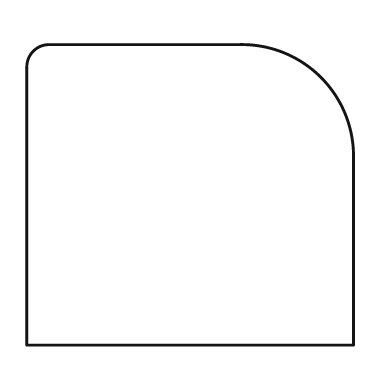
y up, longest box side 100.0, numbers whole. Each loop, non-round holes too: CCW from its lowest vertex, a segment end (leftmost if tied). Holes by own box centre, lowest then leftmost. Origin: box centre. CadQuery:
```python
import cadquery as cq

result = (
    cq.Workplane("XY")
    .moveTo(-50.0, -46.0)
    .lineTo(50.0, -46.0)
    .lineTo(50.0, 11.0)
    .threePointArc((40.0, 36.0), (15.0, 46.0))
    .lineTo(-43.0, 46.0)
    .threePointArc((-48.0, 44.0), (-50.0, 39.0))
    .close()
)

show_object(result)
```